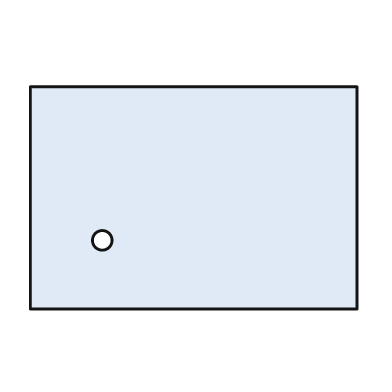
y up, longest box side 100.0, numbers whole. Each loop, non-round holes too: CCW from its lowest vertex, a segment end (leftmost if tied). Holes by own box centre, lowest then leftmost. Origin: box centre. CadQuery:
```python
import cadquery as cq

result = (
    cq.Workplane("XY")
    .moveTo(-50.0, -34.0)
    .lineTo(50.0, -34.0)
    .lineTo(50.0, 34.0)
    .lineTo(-50.0, 34.0)
    .close()
    .moveTo(-28.0, -13.0)
    .circle(3.0)
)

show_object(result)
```